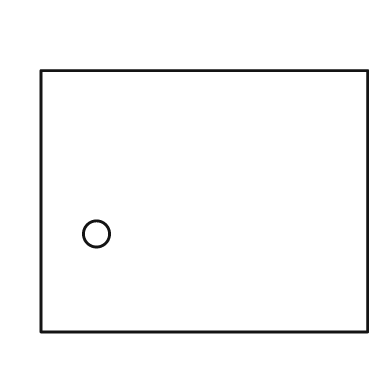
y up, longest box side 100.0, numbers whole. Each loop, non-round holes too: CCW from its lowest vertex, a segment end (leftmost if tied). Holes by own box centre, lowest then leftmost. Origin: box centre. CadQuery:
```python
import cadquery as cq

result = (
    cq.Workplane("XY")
    .moveTo(-50.0, -40.0)
    .lineTo(50.0, -40.0)
    .lineTo(50.0, 40.0)
    .lineTo(-50.0, 40.0)
    .close()
    .moveTo(-33.0, -10.0)
    .circle(4.0)
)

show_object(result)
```